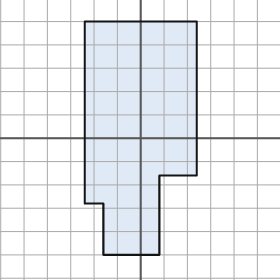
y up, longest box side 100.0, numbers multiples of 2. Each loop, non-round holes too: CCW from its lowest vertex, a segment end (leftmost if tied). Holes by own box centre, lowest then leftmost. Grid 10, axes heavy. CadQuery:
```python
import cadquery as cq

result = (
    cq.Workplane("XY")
    .moveTo(-16.0, -50.0)
    .lineTo(8.0, -50.0)
    .lineTo(8.0, -16.0)
    .lineTo(24.0, -16.0)
    .lineTo(24.0, 50.0)
    .lineTo(-24.0, 50.0)
    .lineTo(-24.0, -28.0)
    .lineTo(-16.0, -28.0)
    .close()
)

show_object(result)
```